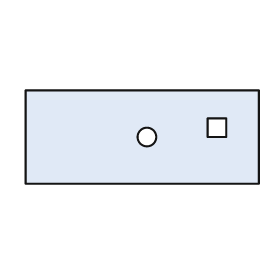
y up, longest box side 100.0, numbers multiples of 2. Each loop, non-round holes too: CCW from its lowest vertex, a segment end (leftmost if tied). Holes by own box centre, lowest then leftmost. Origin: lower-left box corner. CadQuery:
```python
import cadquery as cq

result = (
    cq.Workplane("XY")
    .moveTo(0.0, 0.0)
    .lineTo(100.0, 0.0)
    .lineTo(100.0, 40.0)
    .lineTo(0.0, 40.0)
    .close()
    .moveTo(52.0, 20.0)
    .circle(4.0)
    .moveTo(78.0, 20.0)
    .lineTo(86.0, 20.0)
    .lineTo(86.0, 28.0)
    .lineTo(78.0, 28.0)
    .close()
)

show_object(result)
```